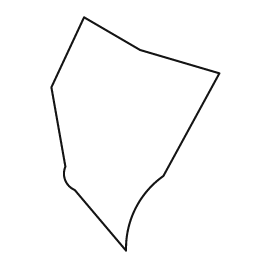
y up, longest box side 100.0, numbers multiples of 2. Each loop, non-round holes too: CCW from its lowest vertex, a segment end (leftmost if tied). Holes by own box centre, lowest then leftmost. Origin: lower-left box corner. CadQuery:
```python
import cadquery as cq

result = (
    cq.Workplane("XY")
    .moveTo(32.0, 0.0)
    .threePointArc((36.0, 18.0), (48.0, 32.0))
    .lineTo(72.0, 76.0)
    .lineTo(38.0, 86.0)
    .lineTo(14.0, 100.0)
    .lineTo(0.0, 70.0)
    .lineTo(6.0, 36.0)
    .threePointArc((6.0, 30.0), (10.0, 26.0))
    .close()
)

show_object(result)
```